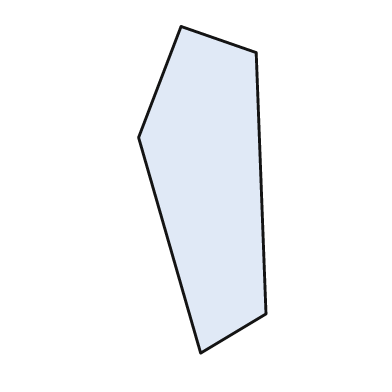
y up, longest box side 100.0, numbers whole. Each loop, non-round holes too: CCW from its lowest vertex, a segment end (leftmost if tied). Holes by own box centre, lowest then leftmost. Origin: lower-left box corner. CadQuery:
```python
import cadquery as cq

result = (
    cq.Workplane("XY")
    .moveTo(19.0, 0.0)
    .lineTo(39.0, 12.0)
    .lineTo(36.0, 92.0)
    .lineTo(13.0, 100.0)
    .lineTo(0.0, 66.0)
    .close()
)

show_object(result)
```